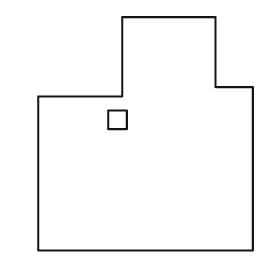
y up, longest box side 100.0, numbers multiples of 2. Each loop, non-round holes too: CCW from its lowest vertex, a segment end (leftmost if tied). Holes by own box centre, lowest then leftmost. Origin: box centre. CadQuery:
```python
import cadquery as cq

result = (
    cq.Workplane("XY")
    .moveTo(-46.0, -50.0)
    .lineTo(46.0, -50.0)
    .lineTo(46.0, 20.0)
    .lineTo(30.0, 20.0)
    .lineTo(30.0, 50.0)
    .lineTo(-10.0, 50.0)
    .lineTo(-10.0, 16.0)
    .lineTo(-46.0, 16.0)
    .close()
    .moveTo(-16.0, 2.0)
    .lineTo(-8.0, 2.0)
    .lineTo(-8.0, 10.0)
    .lineTo(-16.0, 10.0)
    .close()
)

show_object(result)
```